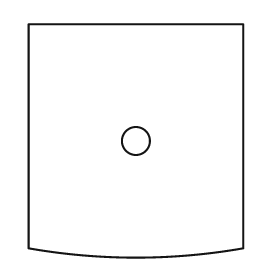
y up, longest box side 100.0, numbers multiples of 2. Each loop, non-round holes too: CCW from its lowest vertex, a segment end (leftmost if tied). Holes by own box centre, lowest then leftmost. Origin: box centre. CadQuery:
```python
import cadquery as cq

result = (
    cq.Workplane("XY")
    .moveTo(-46.0, -46.0)
    .threePointArc((0.0, -50.0), (46.0, -46.0))
    .lineTo(46.0, 50.0)
    .lineTo(-46.0, 50.0)
    .close()
    .moveTo(0.0, 0.0)
    .circle(6.0)
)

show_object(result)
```